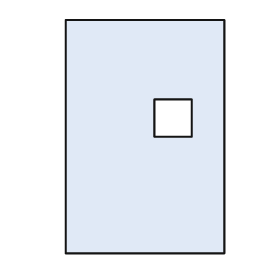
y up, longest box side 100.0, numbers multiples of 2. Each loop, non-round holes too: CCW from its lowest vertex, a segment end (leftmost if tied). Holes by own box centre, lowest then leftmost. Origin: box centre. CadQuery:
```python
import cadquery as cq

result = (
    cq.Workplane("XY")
    .moveTo(-34.0, -50.0)
    .lineTo(34.0, -50.0)
    .lineTo(34.0, 50.0)
    .lineTo(-34.0, 50.0)
    .close()
    .moveTo(4.0, 0.0)
    .lineTo(20.0, 0.0)
    .lineTo(20.0, 16.0)
    .lineTo(4.0, 16.0)
    .close()
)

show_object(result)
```